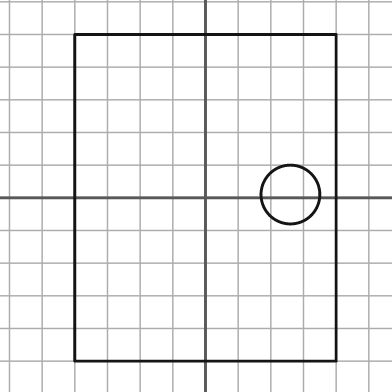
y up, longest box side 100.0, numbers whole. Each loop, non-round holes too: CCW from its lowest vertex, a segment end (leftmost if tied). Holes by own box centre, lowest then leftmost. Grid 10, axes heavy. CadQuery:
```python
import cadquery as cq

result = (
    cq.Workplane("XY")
    .moveTo(-40.0, -50.0)
    .lineTo(40.0, -50.0)
    .lineTo(40.0, 50.0)
    .lineTo(-40.0, 50.0)
    .close()
    .moveTo(26.0, 1.0)
    .circle(9.0)
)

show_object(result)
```